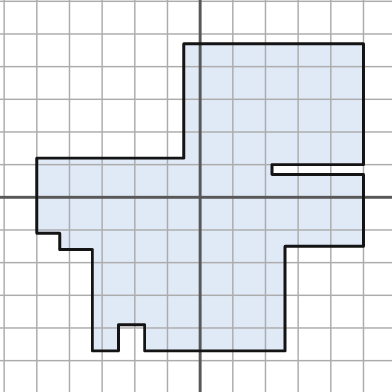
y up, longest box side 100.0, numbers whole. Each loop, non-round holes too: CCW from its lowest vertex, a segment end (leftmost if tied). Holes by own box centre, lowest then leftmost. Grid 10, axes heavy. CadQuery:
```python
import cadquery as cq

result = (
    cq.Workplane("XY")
    .moveTo(-33.0, -47.0)
    .lineTo(-25.0, -47.0)
    .lineTo(-25.0, -39.0)
    .lineTo(-17.0, -39.0)
    .lineTo(-17.0, -47.0)
    .lineTo(26.0, -47.0)
    .lineTo(26.0, -15.0)
    .lineTo(50.0, -15.0)
    .lineTo(50.0, 7.0)
    .lineTo(22.0, 7.0)
    .lineTo(22.0, 10.0)
    .lineTo(50.0, 10.0)
    .lineTo(50.0, 47.0)
    .lineTo(-5.0, 47.0)
    .lineTo(-5.0, 12.0)
    .lineTo(-50.0, 12.0)
    .lineTo(-50.0, -11.0)
    .lineTo(-43.0, -11.0)
    .lineTo(-43.0, -16.0)
    .lineTo(-33.0, -16.0)
    .close()
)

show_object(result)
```